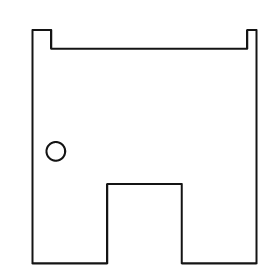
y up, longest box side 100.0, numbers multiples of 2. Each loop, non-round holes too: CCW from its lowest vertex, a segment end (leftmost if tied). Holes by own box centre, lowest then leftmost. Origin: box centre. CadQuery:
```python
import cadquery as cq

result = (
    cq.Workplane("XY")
    .moveTo(-48.0, -50.0)
    .lineTo(-16.0, -50.0)
    .lineTo(-16.0, -16.0)
    .lineTo(16.0, -16.0)
    .lineTo(16.0, -50.0)
    .lineTo(48.0, -50.0)
    .lineTo(48.0, 50.0)
    .lineTo(44.0, 50.0)
    .lineTo(44.0, 42.0)
    .lineTo(-40.0, 42.0)
    .lineTo(-40.0, 50.0)
    .lineTo(-48.0, 50.0)
    .close()
    .moveTo(-38.0, -2.0)
    .circle(4.0)
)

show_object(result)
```